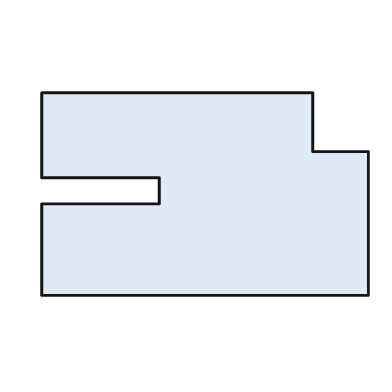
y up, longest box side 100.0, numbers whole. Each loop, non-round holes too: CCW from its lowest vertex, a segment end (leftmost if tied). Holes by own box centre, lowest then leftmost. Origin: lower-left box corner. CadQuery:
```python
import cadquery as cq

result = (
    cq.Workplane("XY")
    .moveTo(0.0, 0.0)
    .lineTo(100.0, 0.0)
    .lineTo(100.0, 44.0)
    .lineTo(83.0, 44.0)
    .lineTo(83.0, 62.0)
    .lineTo(0.0, 62.0)
    .lineTo(0.0, 36.0)
    .lineTo(36.0, 36.0)
    .lineTo(36.0, 28.0)
    .lineTo(0.0, 28.0)
    .close()
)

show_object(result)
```